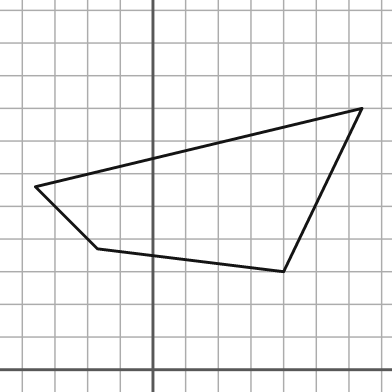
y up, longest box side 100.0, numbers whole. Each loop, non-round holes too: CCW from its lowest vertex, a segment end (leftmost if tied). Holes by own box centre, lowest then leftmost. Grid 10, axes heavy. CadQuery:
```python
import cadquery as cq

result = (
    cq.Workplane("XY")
    .moveTo(40.0, 30.0)
    .lineTo(64.0, 80.0)
    .lineTo(-36.0, 56.0)
    .lineTo(-17.0, 37.0)
    .close()
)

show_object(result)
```